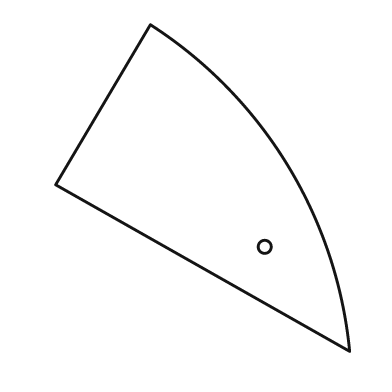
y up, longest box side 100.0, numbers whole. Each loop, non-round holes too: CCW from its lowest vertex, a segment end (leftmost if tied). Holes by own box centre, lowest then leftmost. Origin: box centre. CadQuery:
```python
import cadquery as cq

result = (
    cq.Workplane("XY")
    .moveTo(45.0, -50.0)
    .threePointArc((26.0, 7.0), (-16.0, 50.0))
    .lineTo(-45.0, 1.0)
    .close()
    .moveTo(19.0, -18.0)
    .circle(2.0)
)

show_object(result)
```